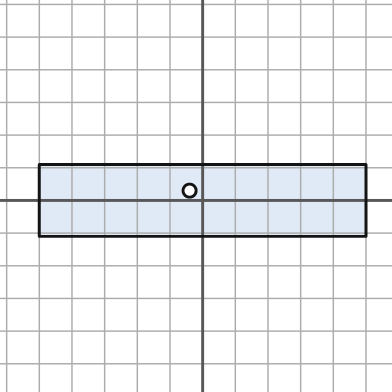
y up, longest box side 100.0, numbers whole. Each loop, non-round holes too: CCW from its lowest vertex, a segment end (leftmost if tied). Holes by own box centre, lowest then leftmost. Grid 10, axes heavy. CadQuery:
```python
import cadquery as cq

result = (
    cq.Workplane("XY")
    .moveTo(-50.0, -11.0)
    .lineTo(50.0, -11.0)
    .lineTo(50.0, 11.0)
    .lineTo(-50.0, 11.0)
    .close()
    .moveTo(-4.0, 3.0)
    .circle(2.0)
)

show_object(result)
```